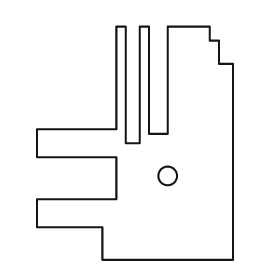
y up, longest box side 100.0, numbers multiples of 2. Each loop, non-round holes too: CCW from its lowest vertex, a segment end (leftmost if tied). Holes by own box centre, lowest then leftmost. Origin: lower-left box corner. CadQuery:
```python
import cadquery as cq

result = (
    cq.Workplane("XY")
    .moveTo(28.0, 0.0)
    .lineTo(84.0, 0.0)
    .lineTo(84.0, 84.0)
    .lineTo(78.0, 84.0)
    .lineTo(78.0, 94.0)
    .lineTo(74.0, 94.0)
    .lineTo(74.0, 100.0)
    .lineTo(56.0, 100.0)
    .lineTo(56.0, 54.0)
    .lineTo(48.0, 54.0)
    .lineTo(48.0, 100.0)
    .lineTo(44.0, 100.0)
    .lineTo(44.0, 50.0)
    .lineTo(38.0, 50.0)
    .lineTo(38.0, 100.0)
    .lineTo(34.0, 100.0)
    .lineTo(34.0, 56.0)
    .lineTo(0.0, 56.0)
    .lineTo(0.0, 44.0)
    .lineTo(34.0, 44.0)
    .lineTo(34.0, 26.0)
    .lineTo(0.0, 26.0)
    .lineTo(0.0, 14.0)
    .lineTo(28.0, 14.0)
    .close()
    .moveTo(56.0, 36.0)
    .circle(4.0)
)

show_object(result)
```